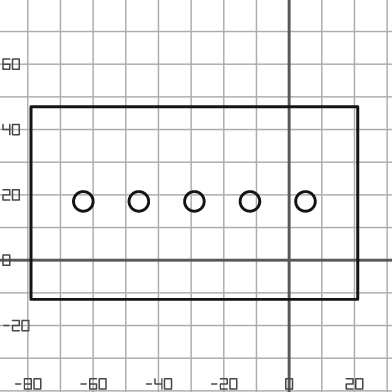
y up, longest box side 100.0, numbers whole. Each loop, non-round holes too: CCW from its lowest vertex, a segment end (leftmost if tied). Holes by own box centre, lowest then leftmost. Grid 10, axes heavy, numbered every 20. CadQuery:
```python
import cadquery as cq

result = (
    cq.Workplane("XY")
    .moveTo(-79.0, -12.0)
    .lineTo(21.0, -12.0)
    .lineTo(21.0, 47.0)
    .lineTo(-79.0, 47.0)
    .close()
    .moveTo(-63.0, 18.0)
    .circle(3.0)
    .moveTo(-46.0, 18.0)
    .circle(3.0)
    .moveTo(-29.0, 18.0)
    .circle(3.0)
    .moveTo(-12.0, 18.0)
    .circle(3.0)
    .moveTo(5.0, 18.0)
    .circle(3.0)
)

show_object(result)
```